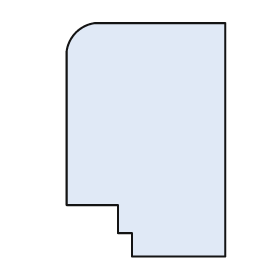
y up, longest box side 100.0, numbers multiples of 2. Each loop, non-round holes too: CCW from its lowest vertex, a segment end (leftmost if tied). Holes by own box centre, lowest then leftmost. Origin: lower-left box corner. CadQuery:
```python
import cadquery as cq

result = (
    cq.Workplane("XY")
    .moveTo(28.0, 0.0)
    .lineTo(68.0, 0.0)
    .lineTo(68.0, 100.0)
    .lineTo(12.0, 100.0)
    .threePointArc((4.0, 96.0), (0.0, 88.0))
    .lineTo(0.0, 22.0)
    .lineTo(22.0, 22.0)
    .lineTo(22.0, 10.0)
    .lineTo(28.0, 10.0)
    .close()
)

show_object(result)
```